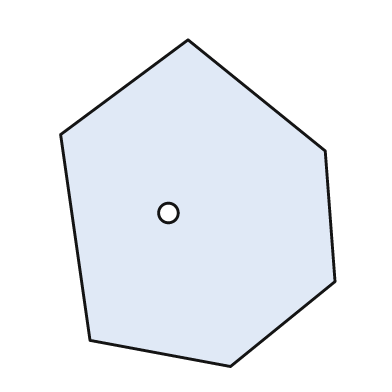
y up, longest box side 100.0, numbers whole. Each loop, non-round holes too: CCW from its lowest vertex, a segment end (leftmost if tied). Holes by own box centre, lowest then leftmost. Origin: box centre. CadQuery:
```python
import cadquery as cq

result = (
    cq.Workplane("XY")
    .moveTo(10.0, -50.0)
    .lineTo(42.0, -24.0)
    .lineTo(39.0, 16.0)
    .lineTo(-3.0, 50.0)
    .lineTo(-42.0, 21.0)
    .lineTo(-33.0, -42.0)
    .close()
    .moveTo(-9.0, -3.0)
    .circle(3.0)
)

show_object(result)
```